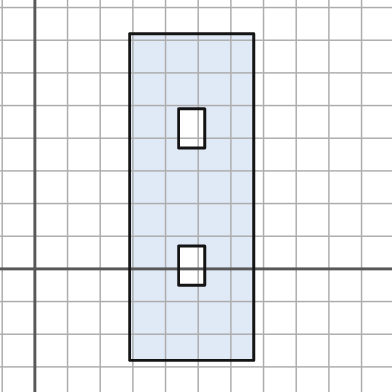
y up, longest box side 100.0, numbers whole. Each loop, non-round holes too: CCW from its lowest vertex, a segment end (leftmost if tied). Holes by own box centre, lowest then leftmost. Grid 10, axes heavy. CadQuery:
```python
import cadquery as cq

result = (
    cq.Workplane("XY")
    .moveTo(29.0, -28.0)
    .lineTo(67.0, -28.0)
    .lineTo(67.0, 72.0)
    .lineTo(29.0, 72.0)
    .close()
    .moveTo(44.0, -5.0)
    .lineTo(52.0, -5.0)
    .lineTo(52.0, 7.0)
    .lineTo(44.0, 7.0)
    .close()
    .moveTo(44.0, 37.0)
    .lineTo(52.0, 37.0)
    .lineTo(52.0, 49.0)
    .lineTo(44.0, 49.0)
    .close()
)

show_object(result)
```